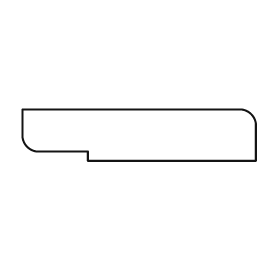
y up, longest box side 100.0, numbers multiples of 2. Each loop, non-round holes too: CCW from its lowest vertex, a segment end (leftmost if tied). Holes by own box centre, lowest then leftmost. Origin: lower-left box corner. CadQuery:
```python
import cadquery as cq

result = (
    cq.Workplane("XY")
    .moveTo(28.0, 0.0)
    .lineTo(100.0, 0.0)
    .lineTo(100.0, 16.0)
    .threePointArc((98.0, 20.0), (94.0, 22.0))
    .lineTo(0.0, 22.0)
    .lineTo(0.0, 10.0)
    .threePointArc((2.0, 6.0), (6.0, 4.0))
    .lineTo(28.0, 4.0)
    .close()
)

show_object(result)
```